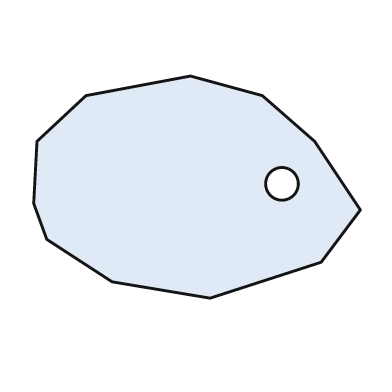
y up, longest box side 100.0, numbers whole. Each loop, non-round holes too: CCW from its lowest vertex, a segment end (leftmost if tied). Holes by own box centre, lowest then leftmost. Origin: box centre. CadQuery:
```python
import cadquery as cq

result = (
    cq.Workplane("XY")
    .moveTo(4.0, -34.0)
    .lineTo(38.0, -23.0)
    .lineTo(50.0, -7.0)
    .lineTo(36.0, 14.0)
    .lineTo(20.0, 28.0)
    .lineTo(-2.0, 34.0)
    .lineTo(-34.0, 28.0)
    .lineTo(-49.0, 14.0)
    .lineTo(-50.0, -5.0)
    .lineTo(-46.0, -16.0)
    .lineTo(-26.0, -29.0)
    .close()
    .moveTo(26.0, 1.0)
    .circle(5.0)
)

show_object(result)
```